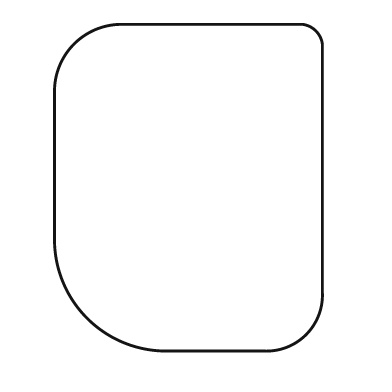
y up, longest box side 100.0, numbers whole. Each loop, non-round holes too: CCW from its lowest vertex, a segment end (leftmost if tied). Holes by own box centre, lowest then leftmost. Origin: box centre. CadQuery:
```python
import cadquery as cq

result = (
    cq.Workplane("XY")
    .moveTo(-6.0, -50.0)
    .lineTo(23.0, -50.0)
    .threePointArc((36.0, -45.0), (41.0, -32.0))
    .lineTo(41.0, 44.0)
    .threePointArc((39.0, 48.0), (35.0, 50.0))
    .lineTo(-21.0, 50.0)
    .threePointArc((-35.0, 44.0), (-41.0, 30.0))
    .lineTo(-41.0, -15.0)
    .threePointArc((-31.0, -40.0), (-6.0, -50.0))
    .close()
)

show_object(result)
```